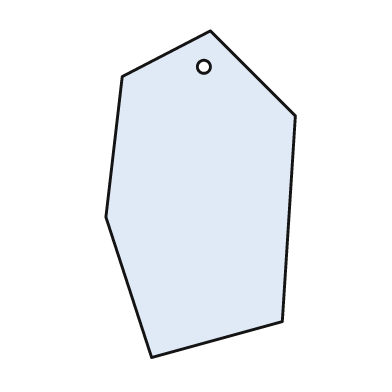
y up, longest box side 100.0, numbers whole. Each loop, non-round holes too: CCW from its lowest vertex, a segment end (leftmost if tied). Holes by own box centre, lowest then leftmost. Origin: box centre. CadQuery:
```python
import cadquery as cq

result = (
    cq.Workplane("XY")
    .moveTo(-15.0, -50.0)
    .lineTo(25.0, -39.0)
    .lineTo(29.0, 24.0)
    .lineTo(3.0, 50.0)
    .lineTo(-24.0, 36.0)
    .lineTo(-29.0, -7.0)
    .close()
    .moveTo(1.0, 39.0)
    .circle(2.0)
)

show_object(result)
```